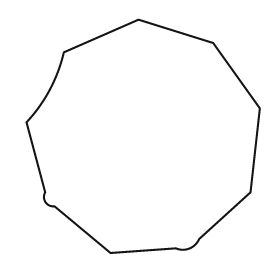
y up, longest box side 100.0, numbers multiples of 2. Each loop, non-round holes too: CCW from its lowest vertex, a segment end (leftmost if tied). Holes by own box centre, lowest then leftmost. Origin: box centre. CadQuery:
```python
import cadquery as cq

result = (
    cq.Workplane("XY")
    .moveTo(-14.0, -50.0)
    .lineTo(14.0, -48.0)
    .threePointArc((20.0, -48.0), (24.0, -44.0))
    .lineTo(46.0, -24.0)
    .lineTo(50.0, 12.0)
    .lineTo(30.0, 40.0)
    .lineTo(-2.0, 50.0)
    .lineTo(-34.0, 36.0)
    .threePointArc((-40.0, 20.0), (-50.0, 6.0))
    .lineTo(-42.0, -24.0)
    .threePointArc((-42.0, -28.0), (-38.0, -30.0))
    .close()
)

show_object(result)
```